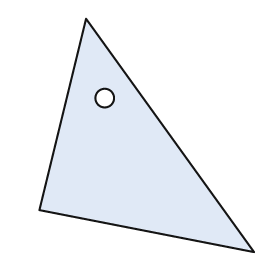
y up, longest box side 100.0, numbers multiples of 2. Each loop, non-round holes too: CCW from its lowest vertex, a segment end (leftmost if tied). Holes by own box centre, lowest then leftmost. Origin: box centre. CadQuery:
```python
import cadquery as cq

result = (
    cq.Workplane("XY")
    .moveTo(46.0, -50.0)
    .lineTo(-26.0, 50.0)
    .lineTo(-46.0, -32.0)
    .close()
    .moveTo(-18.0, 16.0)
    .circle(4.0)
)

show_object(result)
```